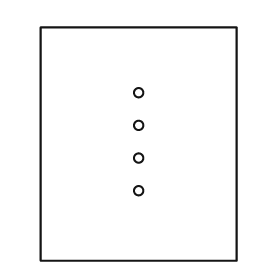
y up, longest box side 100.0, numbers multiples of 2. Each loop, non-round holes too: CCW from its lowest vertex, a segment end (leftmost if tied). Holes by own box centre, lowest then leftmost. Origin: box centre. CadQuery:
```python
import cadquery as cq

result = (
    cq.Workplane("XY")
    .moveTo(-42.0, -50.0)
    .lineTo(42.0, -50.0)
    .lineTo(42.0, 50.0)
    .lineTo(-42.0, 50.0)
    .close()
    .moveTo(0.0, -20.0)
    .circle(2.0)
    .moveTo(0.0, -6.0)
    .circle(2.0)
    .moveTo(0.0, 8.0)
    .circle(2.0)
    .moveTo(0.0, 22.0)
    .circle(2.0)
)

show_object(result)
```